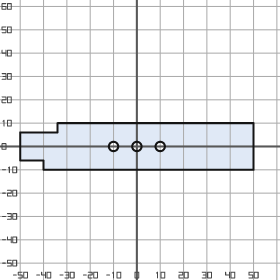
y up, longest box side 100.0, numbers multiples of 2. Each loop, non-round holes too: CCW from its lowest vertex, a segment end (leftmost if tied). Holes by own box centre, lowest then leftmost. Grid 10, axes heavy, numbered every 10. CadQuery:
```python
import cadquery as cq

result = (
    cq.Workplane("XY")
    .moveTo(-40.0, -10.0)
    .lineTo(50.0, -10.0)
    .lineTo(50.0, 10.0)
    .lineTo(-34.0, 10.0)
    .lineTo(-34.0, 6.0)
    .lineTo(-50.0, 6.0)
    .lineTo(-50.0, -6.0)
    .lineTo(-40.0, -6.0)
    .close()
    .moveTo(-10.0, 0.0)
    .circle(2.0)
    .moveTo(0.0, 0.0)
    .circle(2.0)
    .moveTo(10.0, 0.0)
    .circle(2.0)
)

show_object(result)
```